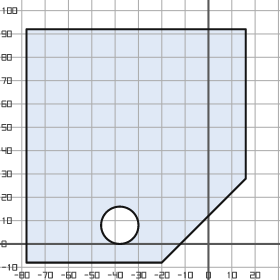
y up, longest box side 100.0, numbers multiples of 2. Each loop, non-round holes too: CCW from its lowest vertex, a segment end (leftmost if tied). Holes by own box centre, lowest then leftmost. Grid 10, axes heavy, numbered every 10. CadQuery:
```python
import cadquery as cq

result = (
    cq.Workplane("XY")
    .moveTo(-78.0, -8.0)
    .lineTo(-20.0, -8.0)
    .lineTo(16.0, 28.0)
    .lineTo(16.0, 92.0)
    .lineTo(-78.0, 92.0)
    .close()
    .moveTo(-38.0, 8.0)
    .circle(8.0)
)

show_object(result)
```